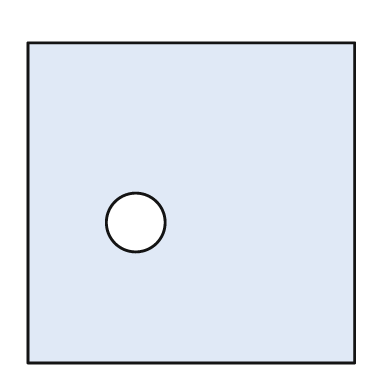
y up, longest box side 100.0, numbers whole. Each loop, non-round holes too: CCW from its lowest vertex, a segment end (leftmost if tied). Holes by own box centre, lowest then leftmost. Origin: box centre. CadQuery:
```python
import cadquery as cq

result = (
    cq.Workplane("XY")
    .moveTo(-50.0, -49.0)
    .lineTo(50.0, -49.0)
    .lineTo(50.0, 49.0)
    .lineTo(-50.0, 49.0)
    .close()
    .moveTo(-17.0, -6.0)
    .circle(9.0)
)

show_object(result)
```